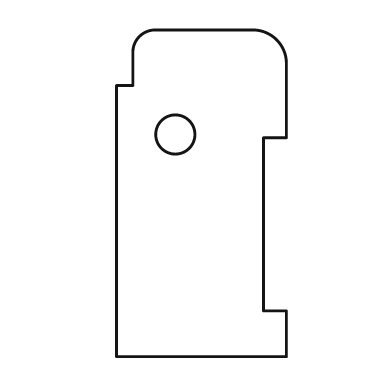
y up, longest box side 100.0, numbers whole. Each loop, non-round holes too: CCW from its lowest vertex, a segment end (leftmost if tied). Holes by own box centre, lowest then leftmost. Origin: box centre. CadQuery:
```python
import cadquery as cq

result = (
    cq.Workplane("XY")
    .moveTo(-26.0, -50.0)
    .lineTo(26.0, -50.0)
    .lineTo(26.0, -36.0)
    .lineTo(19.0, -36.0)
    .lineTo(19.0, 17.0)
    .lineTo(26.0, 17.0)
    .lineTo(26.0, 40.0)
    .threePointArc((23.0, 47.0), (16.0, 50.0))
    .lineTo(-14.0, 50.0)
    .threePointArc((-19.0, 48.0), (-21.0, 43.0))
    .lineTo(-21.0, 33.0)
    .lineTo(-26.0, 33.0)
    .close()
    .moveTo(-8.0, 18.0)
    .circle(6.0)
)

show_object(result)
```